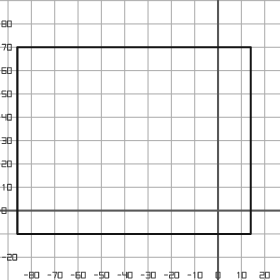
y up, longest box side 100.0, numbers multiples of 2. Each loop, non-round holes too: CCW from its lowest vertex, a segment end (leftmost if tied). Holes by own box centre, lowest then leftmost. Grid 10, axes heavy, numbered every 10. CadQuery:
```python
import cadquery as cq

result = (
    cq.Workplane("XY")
    .moveTo(-86.0, -10.0)
    .lineTo(14.0, -10.0)
    .lineTo(14.0, 70.0)
    .lineTo(-86.0, 70.0)
    .close()
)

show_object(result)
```